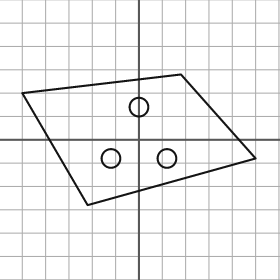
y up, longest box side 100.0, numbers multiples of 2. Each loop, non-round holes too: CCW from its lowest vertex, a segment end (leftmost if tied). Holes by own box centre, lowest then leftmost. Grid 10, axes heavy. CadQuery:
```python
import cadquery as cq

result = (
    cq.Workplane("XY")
    .moveTo(-22.0, -28.0)
    .lineTo(50.0, -8.0)
    .lineTo(18.0, 28.0)
    .lineTo(-50.0, 20.0)
    .close()
    .moveTo(-12.0, -8.0)
    .circle(4.0)
    .moveTo(12.0, -8.0)
    .circle(4.0)
    .moveTo(0.0, 14.0)
    .circle(4.0)
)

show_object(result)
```